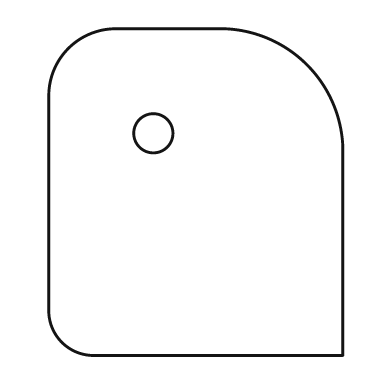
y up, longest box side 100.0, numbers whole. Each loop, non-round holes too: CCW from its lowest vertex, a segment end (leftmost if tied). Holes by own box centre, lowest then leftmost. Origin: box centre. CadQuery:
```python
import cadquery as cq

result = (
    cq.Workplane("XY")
    .moveTo(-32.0, -50.0)
    .lineTo(45.0, -50.0)
    .lineTo(45.0, 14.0)
    .threePointArc((34.0, 39.0), (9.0, 50.0))
    .lineTo(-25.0, 50.0)
    .threePointArc((-39.0, 44.0), (-45.0, 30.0))
    .lineTo(-45.0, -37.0)
    .threePointArc((-41.0, -46.0), (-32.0, -50.0))
    .close()
    .moveTo(-13.0, 18.0)
    .circle(6.0)
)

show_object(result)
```